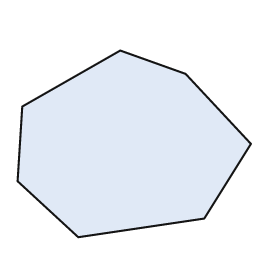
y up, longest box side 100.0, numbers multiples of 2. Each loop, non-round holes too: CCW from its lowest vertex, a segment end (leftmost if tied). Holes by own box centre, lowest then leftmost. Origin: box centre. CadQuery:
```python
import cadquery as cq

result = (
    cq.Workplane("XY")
    .moveTo(-24.0, -40.0)
    .lineTo(30.0, -32.0)
    .lineTo(50.0, 0.0)
    .lineTo(22.0, 30.0)
    .lineTo(-6.0, 40.0)
    .lineTo(-48.0, 16.0)
    .lineTo(-50.0, -16.0)
    .close()
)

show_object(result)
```